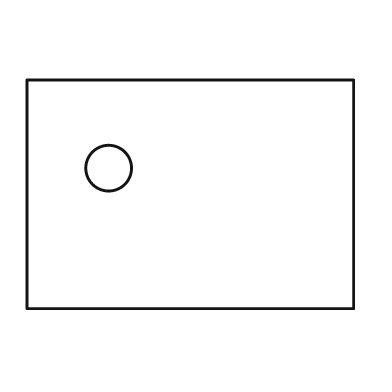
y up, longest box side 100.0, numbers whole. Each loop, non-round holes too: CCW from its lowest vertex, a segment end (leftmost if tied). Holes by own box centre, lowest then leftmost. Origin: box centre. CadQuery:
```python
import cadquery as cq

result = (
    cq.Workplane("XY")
    .moveTo(-50.0, -35.0)
    .lineTo(50.0, -35.0)
    .lineTo(50.0, 35.0)
    .lineTo(-50.0, 35.0)
    .close()
    .moveTo(-25.0, 8.0)
    .circle(7.0)
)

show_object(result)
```